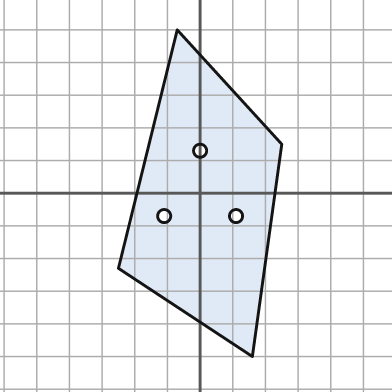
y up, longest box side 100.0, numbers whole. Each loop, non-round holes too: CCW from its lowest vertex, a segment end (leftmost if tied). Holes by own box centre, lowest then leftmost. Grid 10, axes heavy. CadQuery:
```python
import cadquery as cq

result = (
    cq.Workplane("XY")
    .moveTo(16.0, -50.0)
    .lineTo(25.0, 15.0)
    .lineTo(-7.0, 50.0)
    .lineTo(-25.0, -23.0)
    .close()
    .moveTo(-11.0, -7.0)
    .circle(2.0)
    .moveTo(11.0, -7.0)
    .circle(2.0)
    .moveTo(0.0, 13.0)
    .circle(2.0)
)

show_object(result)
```